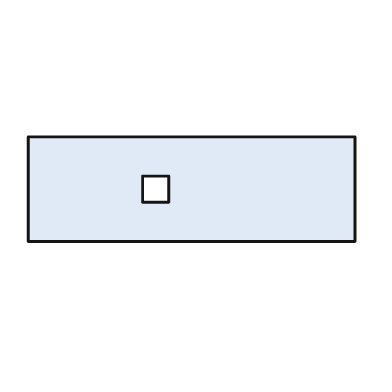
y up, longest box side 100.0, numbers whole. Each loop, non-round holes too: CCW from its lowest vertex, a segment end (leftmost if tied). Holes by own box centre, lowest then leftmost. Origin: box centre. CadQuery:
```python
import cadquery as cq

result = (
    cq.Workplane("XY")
    .moveTo(-50.0, -16.0)
    .lineTo(50.0, -16.0)
    .lineTo(50.0, 16.0)
    .lineTo(-50.0, 16.0)
    .close()
    .moveTo(-15.0, -4.0)
    .lineTo(-7.0, -4.0)
    .lineTo(-7.0, 4.0)
    .lineTo(-15.0, 4.0)
    .close()
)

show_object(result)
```